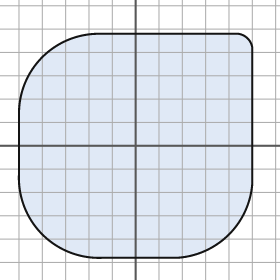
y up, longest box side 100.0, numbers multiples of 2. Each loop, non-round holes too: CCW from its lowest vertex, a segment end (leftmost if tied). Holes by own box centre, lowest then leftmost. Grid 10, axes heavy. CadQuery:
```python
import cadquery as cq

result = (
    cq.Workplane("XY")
    .moveTo(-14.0, -48.0)
    .lineTo(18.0, -48.0)
    .threePointArc((40.0, -38.0), (50.0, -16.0))
    .lineTo(50.0, 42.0)
    .threePointArc((48.0, 46.0), (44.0, 48.0))
    .lineTo(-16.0, 48.0)
    .threePointArc((-40.0, 38.0), (-50.0, 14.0))
    .lineTo(-50.0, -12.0)
    .threePointArc((-40.0, -38.0), (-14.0, -48.0))
    .close()
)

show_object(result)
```